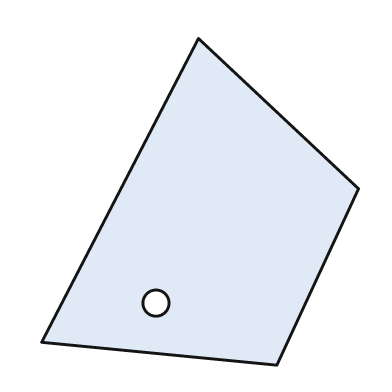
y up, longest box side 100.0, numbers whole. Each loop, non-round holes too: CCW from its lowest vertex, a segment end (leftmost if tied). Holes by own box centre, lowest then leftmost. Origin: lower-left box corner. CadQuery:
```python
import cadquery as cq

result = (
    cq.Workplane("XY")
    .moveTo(72.0, 0.0)
    .lineTo(97.0, 54.0)
    .lineTo(48.0, 100.0)
    .lineTo(0.0, 7.0)
    .close()
    .moveTo(35.0, 19.0)
    .circle(4.0)
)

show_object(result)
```